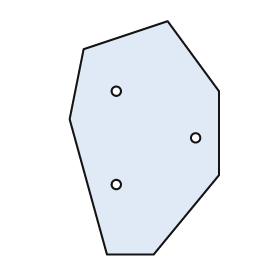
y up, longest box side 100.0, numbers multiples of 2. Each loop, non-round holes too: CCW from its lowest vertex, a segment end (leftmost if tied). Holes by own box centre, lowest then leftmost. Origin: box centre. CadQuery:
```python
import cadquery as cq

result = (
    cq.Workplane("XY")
    .moveTo(-16.0, -50.0)
    .lineTo(4.0, -50.0)
    .lineTo(32.0, -16.0)
    .lineTo(32.0, 20.0)
    .lineTo(10.0, 50.0)
    .lineTo(-26.0, 38.0)
    .lineTo(-32.0, 8.0)
    .close()
    .moveTo(-12.0, -20.0)
    .circle(2.0)
    .moveTo(22.0, 0.0)
    .circle(2.0)
    .moveTo(-12.0, 20.0)
    .circle(2.0)
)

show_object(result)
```